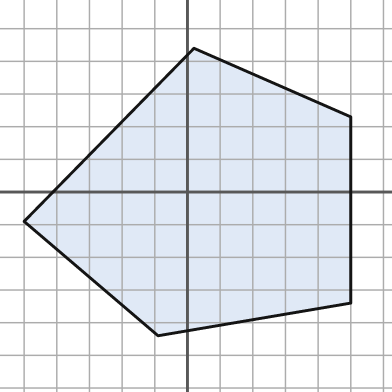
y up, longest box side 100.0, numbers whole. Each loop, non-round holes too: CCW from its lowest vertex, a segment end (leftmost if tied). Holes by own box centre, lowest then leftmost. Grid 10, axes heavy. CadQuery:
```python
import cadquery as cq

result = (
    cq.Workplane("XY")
    .moveTo(-9.0, -44.0)
    .lineTo(50.0, -34.0)
    .lineTo(50.0, 23.0)
    .lineTo(2.0, 44.0)
    .lineTo(-50.0, -9.0)
    .close()
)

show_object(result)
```